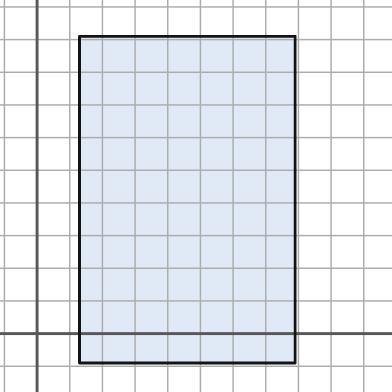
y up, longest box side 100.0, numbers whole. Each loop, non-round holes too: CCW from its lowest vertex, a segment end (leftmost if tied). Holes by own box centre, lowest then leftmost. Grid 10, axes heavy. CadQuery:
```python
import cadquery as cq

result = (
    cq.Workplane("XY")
    .moveTo(13.0, -9.0)
    .lineTo(79.0, -9.0)
    .lineTo(79.0, 91.0)
    .lineTo(13.0, 91.0)
    .close()
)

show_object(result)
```